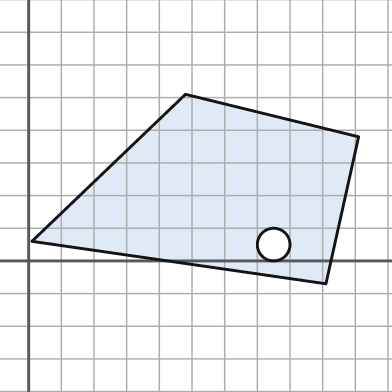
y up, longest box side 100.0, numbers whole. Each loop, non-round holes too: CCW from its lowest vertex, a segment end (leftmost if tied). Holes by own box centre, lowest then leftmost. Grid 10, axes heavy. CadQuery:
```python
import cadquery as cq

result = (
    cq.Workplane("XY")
    .moveTo(91.0, -7.0)
    .lineTo(101.0, 38.0)
    .lineTo(48.0, 51.0)
    .lineTo(1.0, 6.0)
    .close()
    .moveTo(75.0, 5.0)
    .circle(5.0)
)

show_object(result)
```